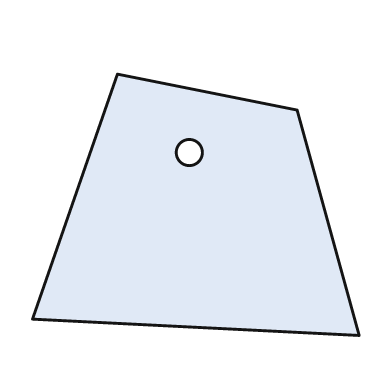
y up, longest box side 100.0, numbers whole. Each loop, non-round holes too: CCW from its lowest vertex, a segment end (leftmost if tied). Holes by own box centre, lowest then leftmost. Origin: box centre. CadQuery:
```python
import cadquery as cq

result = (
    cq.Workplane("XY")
    .moveTo(50.0, -40.0)
    .lineTo(31.0, 29.0)
    .lineTo(-24.0, 40.0)
    .lineTo(-50.0, -35.0)
    .close()
    .moveTo(-2.0, 16.0)
    .circle(4.0)
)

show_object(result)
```